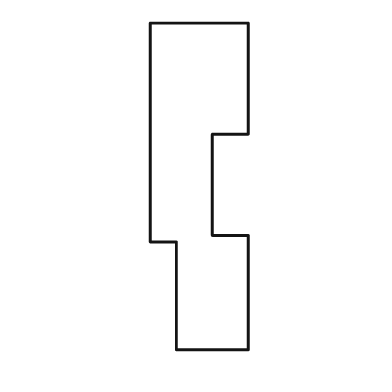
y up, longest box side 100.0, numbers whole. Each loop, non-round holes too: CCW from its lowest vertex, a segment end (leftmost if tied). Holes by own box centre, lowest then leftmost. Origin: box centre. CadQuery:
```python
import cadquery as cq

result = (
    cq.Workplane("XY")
    .moveTo(-7.0, -50.0)
    .lineTo(15.0, -50.0)
    .lineTo(15.0, -15.0)
    .lineTo(4.0, -15.0)
    .lineTo(4.0, 16.0)
    .lineTo(15.0, 16.0)
    .lineTo(15.0, 50.0)
    .lineTo(-15.0, 50.0)
    .lineTo(-15.0, -17.0)
    .lineTo(-7.0, -17.0)
    .close()
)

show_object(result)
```